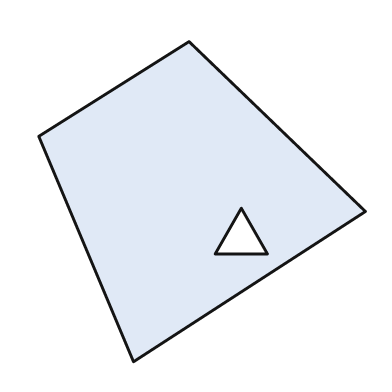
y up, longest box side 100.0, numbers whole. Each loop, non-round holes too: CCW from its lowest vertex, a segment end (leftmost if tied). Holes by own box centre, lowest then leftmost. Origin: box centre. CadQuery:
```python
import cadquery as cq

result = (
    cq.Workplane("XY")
    .moveTo(-21.0, -49.0)
    .lineTo(50.0, -3.0)
    .lineTo(-4.0, 49.0)
    .lineTo(-50.0, 20.0)
    .close()
    .moveTo(4.0, -16.0)
    .lineTo(20.0, -16.0)
    .lineTo(12.0, -2.0)
    .close()
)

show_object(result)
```